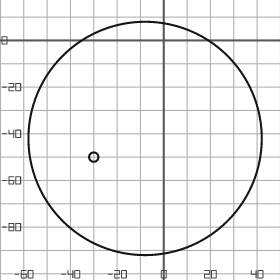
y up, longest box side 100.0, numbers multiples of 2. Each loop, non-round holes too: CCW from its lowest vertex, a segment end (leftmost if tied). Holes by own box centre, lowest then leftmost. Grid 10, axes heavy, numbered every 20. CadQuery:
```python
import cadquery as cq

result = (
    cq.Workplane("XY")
    .moveTo(-8.0, -42.0)
    .circle(50.0)
    .moveTo(-30.0, -50.0)
    .circle(2.0)
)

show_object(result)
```